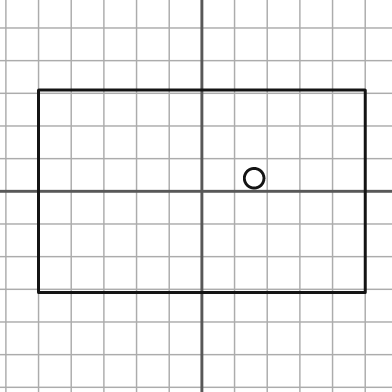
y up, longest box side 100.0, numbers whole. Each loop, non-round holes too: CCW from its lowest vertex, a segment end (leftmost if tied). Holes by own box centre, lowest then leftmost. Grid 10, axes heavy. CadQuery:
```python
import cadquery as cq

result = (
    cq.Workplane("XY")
    .moveTo(-50.0, -31.0)
    .lineTo(50.0, -31.0)
    .lineTo(50.0, 31.0)
    .lineTo(-50.0, 31.0)
    .close()
    .moveTo(16.0, 4.0)
    .circle(3.0)
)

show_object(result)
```